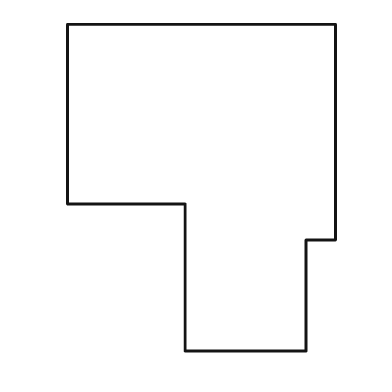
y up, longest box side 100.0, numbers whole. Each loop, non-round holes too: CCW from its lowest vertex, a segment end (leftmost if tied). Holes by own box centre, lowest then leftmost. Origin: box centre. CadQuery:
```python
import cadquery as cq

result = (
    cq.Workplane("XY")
    .moveTo(-5.0, -50.0)
    .lineTo(32.0, -50.0)
    .lineTo(32.0, -16.0)
    .lineTo(41.0, -16.0)
    .lineTo(41.0, 50.0)
    .lineTo(-41.0, 50.0)
    .lineTo(-41.0, -5.0)
    .lineTo(-5.0, -5.0)
    .close()
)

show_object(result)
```